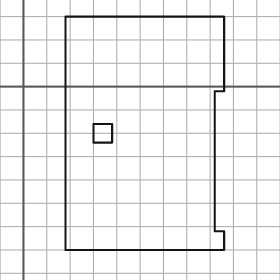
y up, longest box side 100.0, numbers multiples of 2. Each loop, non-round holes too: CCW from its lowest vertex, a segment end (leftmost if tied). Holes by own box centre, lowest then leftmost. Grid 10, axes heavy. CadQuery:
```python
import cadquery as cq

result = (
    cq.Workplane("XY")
    .moveTo(18.0, -70.0)
    .lineTo(86.0, -70.0)
    .lineTo(86.0, -62.0)
    .lineTo(82.0, -62.0)
    .lineTo(82.0, -2.0)
    .lineTo(86.0, -2.0)
    .lineTo(86.0, 30.0)
    .lineTo(18.0, 30.0)
    .close()
    .moveTo(30.0, -24.0)
    .lineTo(38.0, -24.0)
    .lineTo(38.0, -16.0)
    .lineTo(30.0, -16.0)
    .close()
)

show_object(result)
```